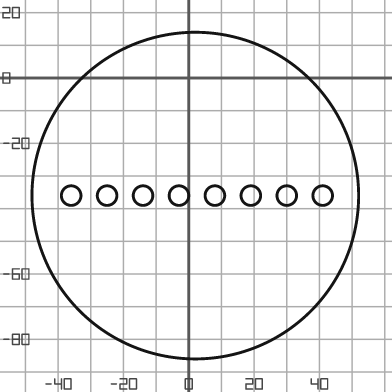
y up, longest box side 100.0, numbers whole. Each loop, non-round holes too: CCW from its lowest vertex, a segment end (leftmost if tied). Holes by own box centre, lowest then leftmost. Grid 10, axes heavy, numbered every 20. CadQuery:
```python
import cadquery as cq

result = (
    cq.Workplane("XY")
    .moveTo(2.0, -36.0)
    .circle(50.0)
    .moveTo(-36.0, -36.0)
    .circle(3.0)
    .moveTo(-25.0, -36.0)
    .circle(3.0)
    .moveTo(-14.0, -36.0)
    .circle(3.0)
    .moveTo(-3.0, -36.0)
    .circle(3.0)
    .moveTo(8.0, -36.0)
    .circle(3.0)
    .moveTo(19.0, -36.0)
    .circle(3.0)
    .moveTo(30.0, -36.0)
    .circle(3.0)
    .moveTo(41.0, -36.0)
    .circle(3.0)
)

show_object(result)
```